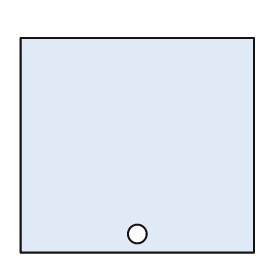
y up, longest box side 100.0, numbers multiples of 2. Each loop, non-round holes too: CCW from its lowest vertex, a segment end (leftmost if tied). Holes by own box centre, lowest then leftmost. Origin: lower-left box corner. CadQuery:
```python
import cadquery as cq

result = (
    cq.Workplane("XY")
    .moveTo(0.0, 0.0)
    .lineTo(100.0, 0.0)
    .lineTo(100.0, 92.0)
    .lineTo(0.0, 92.0)
    .close()
    .moveTo(50.0, 8.0)
    .circle(4.0)
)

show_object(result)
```